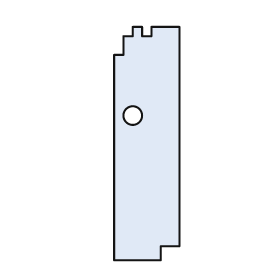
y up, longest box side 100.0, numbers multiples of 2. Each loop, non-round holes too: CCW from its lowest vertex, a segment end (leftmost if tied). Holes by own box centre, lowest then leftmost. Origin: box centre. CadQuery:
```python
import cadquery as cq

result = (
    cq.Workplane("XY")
    .moveTo(-14.0, -50.0)
    .lineTo(6.0, -50.0)
    .lineTo(6.0, -44.0)
    .lineTo(14.0, -44.0)
    .lineTo(14.0, 50.0)
    .lineTo(2.0, 50.0)
    .lineTo(2.0, 46.0)
    .lineTo(-2.0, 46.0)
    .lineTo(-2.0, 50.0)
    .lineTo(-6.0, 50.0)
    .lineTo(-6.0, 46.0)
    .lineTo(-10.0, 46.0)
    .lineTo(-10.0, 38.0)
    .lineTo(-14.0, 38.0)
    .close()
    .moveTo(-6.0, 12.0)
    .circle(4.0)
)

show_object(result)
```